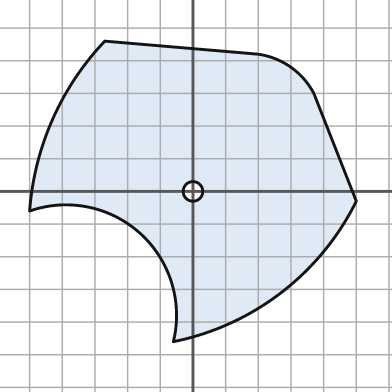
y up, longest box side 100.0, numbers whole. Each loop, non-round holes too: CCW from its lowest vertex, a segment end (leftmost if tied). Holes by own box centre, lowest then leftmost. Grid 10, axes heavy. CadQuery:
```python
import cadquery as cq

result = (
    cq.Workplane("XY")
    .moveTo(-6.0, -46.0)
    .threePointArc((27.0, -31.0), (50.0, -3.0))
    .lineTo(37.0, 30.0)
    .threePointArc((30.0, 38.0), (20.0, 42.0))
    .lineTo(-27.0, 46.0)
    .threePointArc((-43.0, 22.0), (-50.0, -6.0))
    .threePointArc((-16.0, -13.0), (-6.0, -46.0))
    .close()
    .moveTo(0.0, 0.0)
    .circle(3.0)
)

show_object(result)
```